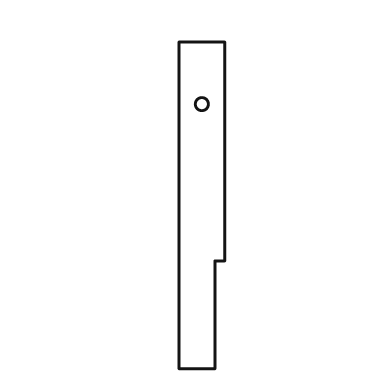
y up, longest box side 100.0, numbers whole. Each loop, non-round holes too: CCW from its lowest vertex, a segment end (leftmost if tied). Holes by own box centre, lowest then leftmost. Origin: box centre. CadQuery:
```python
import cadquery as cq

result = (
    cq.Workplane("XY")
    .moveTo(-7.0, -50.0)
    .lineTo(4.0, -50.0)
    .lineTo(4.0, -17.0)
    .lineTo(7.0, -17.0)
    .lineTo(7.0, 50.0)
    .lineTo(-7.0, 50.0)
    .close()
    .moveTo(0.0, 31.0)
    .circle(2.0)
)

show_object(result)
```